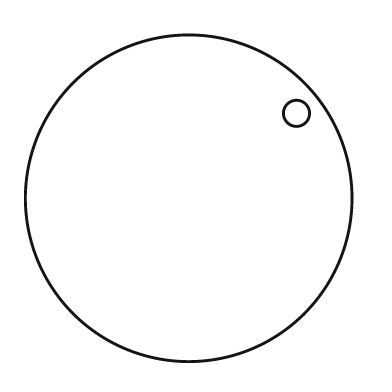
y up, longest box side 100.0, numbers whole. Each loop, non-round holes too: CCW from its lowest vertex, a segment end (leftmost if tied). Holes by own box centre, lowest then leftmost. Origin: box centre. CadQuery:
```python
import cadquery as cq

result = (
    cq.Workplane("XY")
    .moveTo(0.0, 0.0)
    .circle(50.0)
    .moveTo(33.0, 26.0)
    .circle(4.0)
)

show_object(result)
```